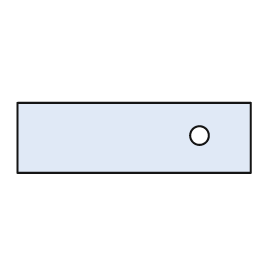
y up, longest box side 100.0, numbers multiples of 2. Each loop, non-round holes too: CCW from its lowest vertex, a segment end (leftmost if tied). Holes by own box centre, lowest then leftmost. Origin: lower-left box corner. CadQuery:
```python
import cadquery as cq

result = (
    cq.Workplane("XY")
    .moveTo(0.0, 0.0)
    .lineTo(100.0, 0.0)
    .lineTo(100.0, 30.0)
    .lineTo(0.0, 30.0)
    .close()
    .moveTo(78.0, 16.0)
    .circle(4.0)
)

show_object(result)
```